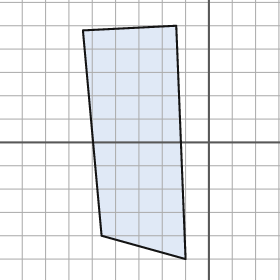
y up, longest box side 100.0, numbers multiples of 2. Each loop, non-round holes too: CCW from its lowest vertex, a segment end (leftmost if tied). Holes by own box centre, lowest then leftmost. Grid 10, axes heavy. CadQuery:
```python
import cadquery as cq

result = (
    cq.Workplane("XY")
    .moveTo(-10.0, -50.0)
    .lineTo(-14.0, 50.0)
    .lineTo(-54.0, 48.0)
    .lineTo(-46.0, -40.0)
    .close()
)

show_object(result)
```